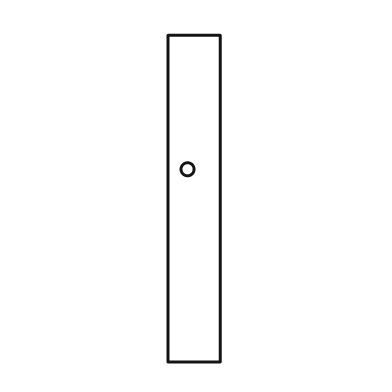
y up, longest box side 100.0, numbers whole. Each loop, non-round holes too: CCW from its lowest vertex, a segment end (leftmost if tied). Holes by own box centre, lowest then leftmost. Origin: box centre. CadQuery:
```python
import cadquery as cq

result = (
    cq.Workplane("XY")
    .moveTo(-8.0, -50.0)
    .lineTo(8.0, -50.0)
    .lineTo(8.0, 50.0)
    .lineTo(-8.0, 50.0)
    .close()
    .moveTo(-2.0, 9.0)
    .circle(2.0)
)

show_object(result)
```